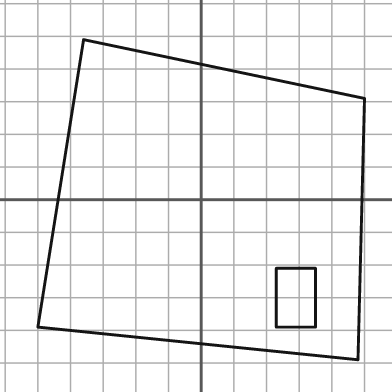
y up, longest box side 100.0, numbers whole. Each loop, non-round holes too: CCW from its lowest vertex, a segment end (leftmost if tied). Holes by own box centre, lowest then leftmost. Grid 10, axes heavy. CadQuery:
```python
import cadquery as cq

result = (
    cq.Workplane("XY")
    .moveTo(48.0, -49.0)
    .lineTo(50.0, 31.0)
    .lineTo(-36.0, 49.0)
    .lineTo(-50.0, -39.0)
    .close()
    .moveTo(23.0, -39.0)
    .lineTo(35.0, -39.0)
    .lineTo(35.0, -21.0)
    .lineTo(23.0, -21.0)
    .close()
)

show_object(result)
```